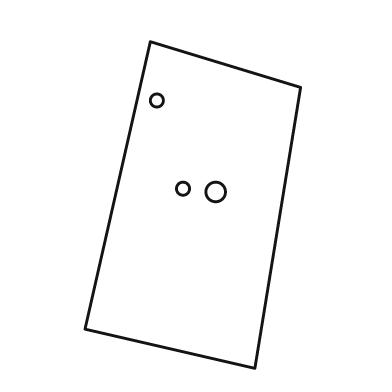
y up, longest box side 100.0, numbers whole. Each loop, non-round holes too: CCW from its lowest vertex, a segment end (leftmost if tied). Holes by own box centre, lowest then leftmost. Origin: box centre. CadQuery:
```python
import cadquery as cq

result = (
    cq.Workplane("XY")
    .moveTo(19.0, -50.0)
    .lineTo(33.0, 36.0)
    .lineTo(-13.0, 50.0)
    .lineTo(-33.0, -38.0)
    .close()
    .moveTo(7.0, 4.0)
    .circle(3.0)
    .moveTo(-3.0, 5.0)
    .circle(2.0)
    .moveTo(-11.0, 32.0)
    .circle(2.0)
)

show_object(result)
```